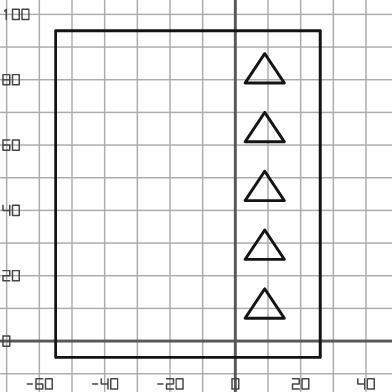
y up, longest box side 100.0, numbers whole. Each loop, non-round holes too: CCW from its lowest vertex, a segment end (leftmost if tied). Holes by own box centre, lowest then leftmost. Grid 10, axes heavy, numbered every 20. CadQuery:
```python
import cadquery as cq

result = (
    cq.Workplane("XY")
    .moveTo(-55.0, -5.0)
    .lineTo(26.0, -5.0)
    .lineTo(26.0, 95.0)
    .lineTo(-55.0, 95.0)
    .close()
    .moveTo(3.0, 7.0)
    .lineTo(15.0, 7.0)
    .lineTo(9.0, 16.0)
    .close()
    .moveTo(3.0, 25.0)
    .lineTo(15.0, 25.0)
    .lineTo(9.0, 34.0)
    .close()
    .moveTo(3.0, 43.0)
    .lineTo(15.0, 43.0)
    .lineTo(9.0, 52.0)
    .close()
    .moveTo(3.0, 61.0)
    .lineTo(15.0, 61.0)
    .lineTo(9.0, 70.0)
    .close()
    .moveTo(3.0, 79.0)
    .lineTo(15.0, 79.0)
    .lineTo(9.0, 88.0)
    .close()
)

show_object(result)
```